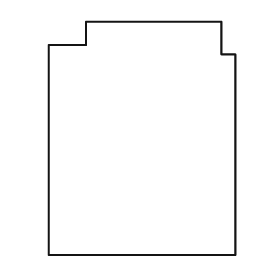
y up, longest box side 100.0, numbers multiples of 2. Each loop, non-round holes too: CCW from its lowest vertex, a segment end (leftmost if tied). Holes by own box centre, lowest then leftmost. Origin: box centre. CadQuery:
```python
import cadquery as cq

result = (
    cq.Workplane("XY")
    .moveTo(-40.0, -50.0)
    .lineTo(40.0, -50.0)
    .lineTo(40.0, 36.0)
    .lineTo(34.0, 36.0)
    .lineTo(34.0, 50.0)
    .lineTo(-24.0, 50.0)
    .lineTo(-24.0, 40.0)
    .lineTo(-40.0, 40.0)
    .close()
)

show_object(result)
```